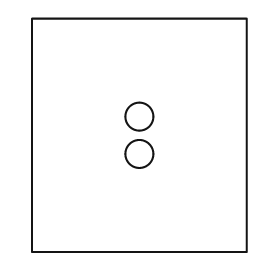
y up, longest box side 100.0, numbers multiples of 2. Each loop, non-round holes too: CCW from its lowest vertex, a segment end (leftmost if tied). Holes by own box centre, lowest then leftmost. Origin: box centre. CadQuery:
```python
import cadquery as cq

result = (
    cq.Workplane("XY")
    .moveTo(-46.0, -50.0)
    .lineTo(46.0, -50.0)
    .lineTo(46.0, 50.0)
    .lineTo(-46.0, 50.0)
    .close()
    .moveTo(0.0, -8.0)
    .circle(6.0)
    .moveTo(0.0, 8.0)
    .circle(6.0)
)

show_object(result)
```